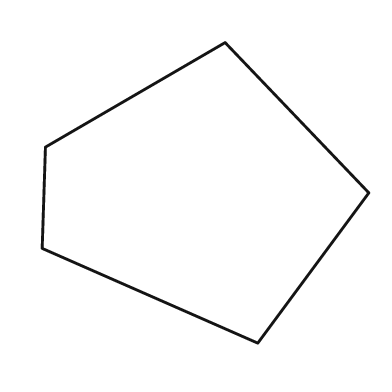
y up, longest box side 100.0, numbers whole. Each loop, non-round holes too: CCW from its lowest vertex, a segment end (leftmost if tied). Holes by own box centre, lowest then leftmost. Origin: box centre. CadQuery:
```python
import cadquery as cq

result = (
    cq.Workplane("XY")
    .moveTo(16.0, -46.0)
    .lineTo(50.0, 0.0)
    .lineTo(6.0, 46.0)
    .lineTo(-49.0, 14.0)
    .lineTo(-50.0, -17.0)
    .close()
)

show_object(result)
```